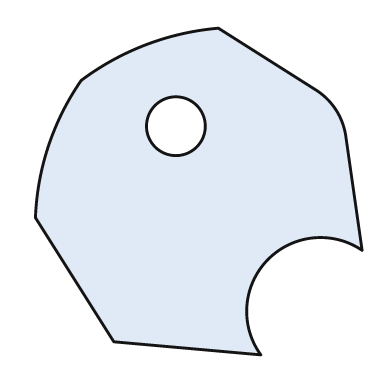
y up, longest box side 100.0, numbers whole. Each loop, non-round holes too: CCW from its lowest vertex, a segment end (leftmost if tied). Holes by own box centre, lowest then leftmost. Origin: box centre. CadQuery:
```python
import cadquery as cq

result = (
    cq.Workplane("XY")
    .moveTo(19.0, -50.0)
    .threePointArc((21.0, -21.0), (50.0, -18.0))
    .lineTo(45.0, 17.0)
    .threePointArc((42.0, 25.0), (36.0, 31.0))
    .lineTo(6.0, 50.0)
    .threePointArc((-16.0, 45.0), (-36.0, 34.0))
    .threePointArc((-46.0, 14.0), (-50.0, -8.0))
    .lineTo(-26.0, -46.0)
    .close()
    .moveTo(-7.0, 20.0)
    .circle(9.0)
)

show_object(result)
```